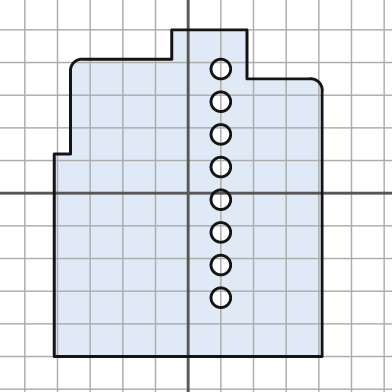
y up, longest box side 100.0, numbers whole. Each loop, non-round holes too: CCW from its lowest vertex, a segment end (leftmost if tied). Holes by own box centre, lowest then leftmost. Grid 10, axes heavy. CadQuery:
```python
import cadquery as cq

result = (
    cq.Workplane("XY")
    .moveTo(-41.0, -50.0)
    .lineTo(41.0, -50.0)
    .lineTo(41.0, 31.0)
    .threePointArc((40.0, 34.0), (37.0, 35.0))
    .lineTo(18.0, 35.0)
    .lineTo(18.0, 50.0)
    .lineTo(-5.0, 50.0)
    .lineTo(-5.0, 41.0)
    .lineTo(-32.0, 41.0)
    .threePointArc((-35.0, 40.0), (-36.0, 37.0))
    .lineTo(-36.0, 12.0)
    .lineTo(-41.0, 12.0)
    .close()
    .moveTo(10.0, -32.0)
    .circle(3.0)
    .moveTo(10.0, -22.0)
    .circle(3.0)
    .moveTo(10.0, -12.0)
    .circle(3.0)
    .moveTo(10.0, -2.0)
    .circle(3.0)
    .moveTo(10.0, 8.0)
    .circle(3.0)
    .moveTo(10.0, 18.0)
    .circle(3.0)
    .moveTo(10.0, 28.0)
    .circle(3.0)
    .moveTo(10.0, 38.0)
    .circle(3.0)
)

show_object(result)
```